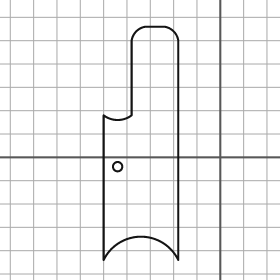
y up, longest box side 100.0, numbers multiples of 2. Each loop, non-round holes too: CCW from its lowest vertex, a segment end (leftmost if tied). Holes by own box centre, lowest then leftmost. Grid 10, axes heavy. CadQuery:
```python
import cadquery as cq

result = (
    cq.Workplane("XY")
    .moveTo(-50.0, -44.0)
    .threePointArc((-34.0, -34.0), (-18.0, -44.0))
    .lineTo(-18.0, 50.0)
    .threePointArc((-20.0, 54.0), (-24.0, 56.0))
    .lineTo(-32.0, 56.0)
    .threePointArc((-36.0, 54.0), (-38.0, 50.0))
    .lineTo(-38.0, 18.0)
    .threePointArc((-44.0, 16.0), (-50.0, 18.0))
    .close()
    .moveTo(-44.0, -4.0)
    .circle(2.0)
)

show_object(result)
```